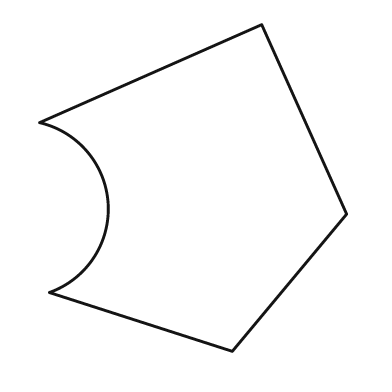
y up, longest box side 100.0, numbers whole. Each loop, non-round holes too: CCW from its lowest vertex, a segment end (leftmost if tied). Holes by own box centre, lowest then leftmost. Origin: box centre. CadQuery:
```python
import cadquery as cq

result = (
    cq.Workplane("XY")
    .moveTo(12.0, -50.0)
    .lineTo(47.0, -8.0)
    .lineTo(21.0, 50.0)
    .lineTo(-47.0, 20.0)
    .threePointArc((-26.0, -5.0), (-44.0, -32.0))
    .close()
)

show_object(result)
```